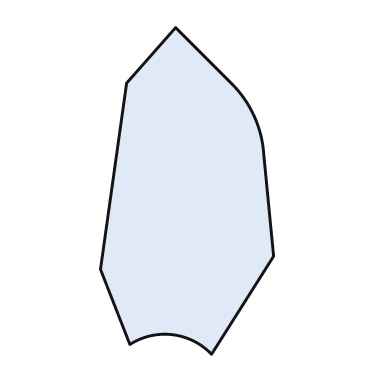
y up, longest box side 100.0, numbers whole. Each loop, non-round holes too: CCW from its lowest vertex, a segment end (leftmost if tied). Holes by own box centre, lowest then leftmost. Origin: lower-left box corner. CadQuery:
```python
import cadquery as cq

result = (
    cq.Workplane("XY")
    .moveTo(34.0, 0.0)
    .lineTo(53.0, 30.0)
    .lineTo(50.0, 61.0)
    .threePointArc((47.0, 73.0), (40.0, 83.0))
    .lineTo(23.0, 100.0)
    .lineTo(8.0, 83.0)
    .lineTo(0.0, 26.0)
    .lineTo(9.0, 3.0)
    .threePointArc((22.0, 6.0), (34.0, 0.0))
    .close()
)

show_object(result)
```